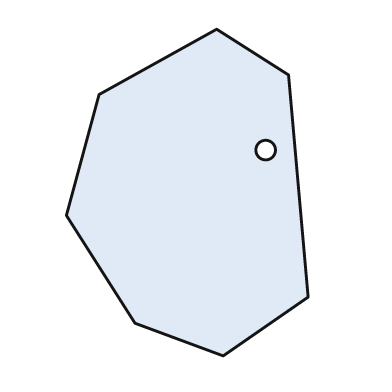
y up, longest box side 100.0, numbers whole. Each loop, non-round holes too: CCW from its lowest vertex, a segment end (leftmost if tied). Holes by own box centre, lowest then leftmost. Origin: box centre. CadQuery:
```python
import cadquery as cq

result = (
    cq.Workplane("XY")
    .moveTo(11.0, -50.0)
    .lineTo(37.0, -32.0)
    .lineTo(31.0, 36.0)
    .lineTo(9.0, 50.0)
    .lineTo(-27.0, 30.0)
    .lineTo(-37.0, -7.0)
    .lineTo(-16.0, -40.0)
    .close()
    .moveTo(24.0, 13.0)
    .circle(3.0)
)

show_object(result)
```